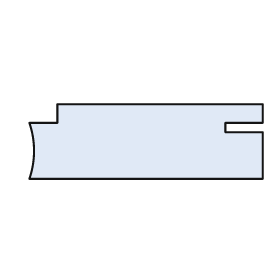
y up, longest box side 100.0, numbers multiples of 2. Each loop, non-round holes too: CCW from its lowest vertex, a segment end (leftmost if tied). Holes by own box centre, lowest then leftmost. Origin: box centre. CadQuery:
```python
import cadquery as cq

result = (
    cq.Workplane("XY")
    .moveTo(-50.0, -16.0)
    .lineTo(50.0, -16.0)
    .lineTo(50.0, 4.0)
    .lineTo(34.0, 4.0)
    .lineTo(34.0, 8.0)
    .lineTo(50.0, 8.0)
    .lineTo(50.0, 16.0)
    .lineTo(-38.0, 16.0)
    .lineTo(-38.0, 8.0)
    .lineTo(-50.0, 8.0)
    .threePointArc((-48.0, -4.0), (-50.0, -16.0))
    .close()
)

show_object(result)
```